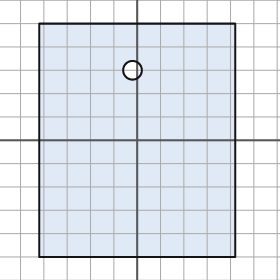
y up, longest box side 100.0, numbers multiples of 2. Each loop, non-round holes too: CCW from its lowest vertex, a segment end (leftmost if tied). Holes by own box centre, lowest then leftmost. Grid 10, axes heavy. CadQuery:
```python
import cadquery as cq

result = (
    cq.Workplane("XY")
    .moveTo(-42.0, -50.0)
    .lineTo(42.0, -50.0)
    .lineTo(42.0, 50.0)
    .lineTo(-42.0, 50.0)
    .close()
    .moveTo(-2.0, 30.0)
    .circle(4.0)
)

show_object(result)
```